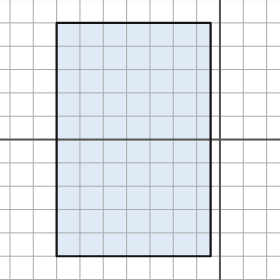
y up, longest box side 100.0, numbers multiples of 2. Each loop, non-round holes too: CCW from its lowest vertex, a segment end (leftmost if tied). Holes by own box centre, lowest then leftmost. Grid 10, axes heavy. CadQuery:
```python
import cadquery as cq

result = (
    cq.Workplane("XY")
    .moveTo(-70.0, -50.0)
    .lineTo(-4.0, -50.0)
    .lineTo(-4.0, 50.0)
    .lineTo(-70.0, 50.0)
    .close()
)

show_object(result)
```